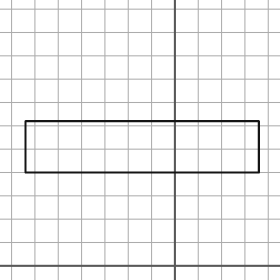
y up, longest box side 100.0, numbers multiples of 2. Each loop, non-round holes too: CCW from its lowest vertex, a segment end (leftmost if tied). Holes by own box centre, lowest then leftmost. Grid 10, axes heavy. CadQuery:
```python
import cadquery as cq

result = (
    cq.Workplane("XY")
    .moveTo(-64.0, 40.0)
    .lineTo(36.0, 40.0)
    .lineTo(36.0, 62.0)
    .lineTo(-64.0, 62.0)
    .close()
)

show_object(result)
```